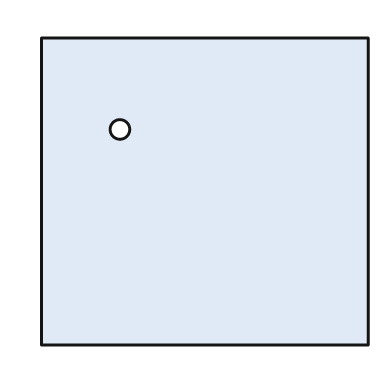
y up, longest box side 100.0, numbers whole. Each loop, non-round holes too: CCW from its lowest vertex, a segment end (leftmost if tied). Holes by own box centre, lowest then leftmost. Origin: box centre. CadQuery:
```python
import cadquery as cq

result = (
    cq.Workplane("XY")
    .moveTo(-50.0, -47.0)
    .lineTo(50.0, -47.0)
    .lineTo(50.0, 47.0)
    .lineTo(-50.0, 47.0)
    .close()
    .moveTo(-26.0, 19.0)
    .circle(3.0)
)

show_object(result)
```